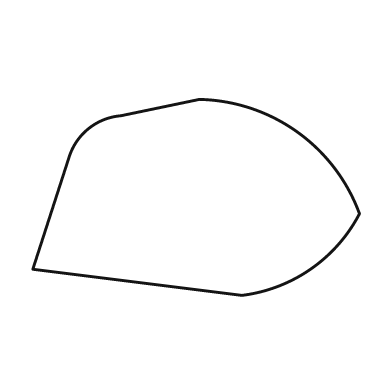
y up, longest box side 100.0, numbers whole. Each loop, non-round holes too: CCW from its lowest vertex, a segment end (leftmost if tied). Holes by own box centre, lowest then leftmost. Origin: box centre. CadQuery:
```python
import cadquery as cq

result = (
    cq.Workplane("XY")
    .moveTo(14.0, -30.0)
    .threePointArc((35.0, -22.0), (50.0, -5.0))
    .threePointArc((31.0, 20.0), (1.0, 30.0))
    .lineTo(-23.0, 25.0)
    .threePointArc((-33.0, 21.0), (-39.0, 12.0))
    .lineTo(-50.0, -22.0)
    .close()
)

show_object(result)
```